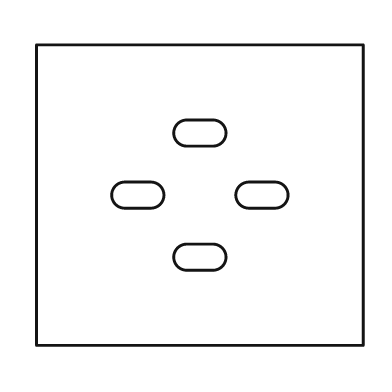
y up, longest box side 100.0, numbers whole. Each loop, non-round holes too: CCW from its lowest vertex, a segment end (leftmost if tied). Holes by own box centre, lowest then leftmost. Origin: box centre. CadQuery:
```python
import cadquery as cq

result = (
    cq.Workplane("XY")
    .moveTo(-50.0, -46.0)
    .lineTo(50.0, -46.0)
    .lineTo(50.0, 46.0)
    .lineTo(-50.0, 46.0)
    .close()
    .moveTo(-4.0, -23.0)
    .lineTo(4.0, -23.0)
    .threePointArc((8.0, -19.0), (4.0, -15.0))
    .lineTo(-4.0, -15.0)
    .threePointArc((-8.0, -19.0), (-4.0, -23.0))
    .close()
    .moveTo(-23.0, -4.0)
    .lineTo(-15.0, -4.0)
    .threePointArc((-11.0, 0.0), (-15.0, 4.0))
    .lineTo(-23.0, 4.0)
    .threePointArc((-27.0, 0.0), (-23.0, -4.0))
    .close()
    .moveTo(15.0, -4.0)
    .lineTo(23.0, -4.0)
    .threePointArc((27.0, 0.0), (23.0, 4.0))
    .lineTo(15.0, 4.0)
    .threePointArc((11.0, 0.0), (15.0, -4.0))
    .close()
    .moveTo(-4.0, 15.0)
    .lineTo(4.0, 15.0)
    .threePointArc((8.0, 19.0), (4.0, 23.0))
    .lineTo(-4.0, 23.0)
    .threePointArc((-8.0, 19.0), (-4.0, 15.0))
    .close()
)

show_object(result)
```